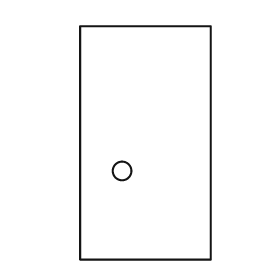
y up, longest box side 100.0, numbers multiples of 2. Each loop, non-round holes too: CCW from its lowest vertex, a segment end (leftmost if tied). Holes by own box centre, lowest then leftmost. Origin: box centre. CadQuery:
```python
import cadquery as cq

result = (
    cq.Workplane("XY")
    .moveTo(-28.0, -50.0)
    .lineTo(28.0, -50.0)
    .lineTo(28.0, 50.0)
    .lineTo(-28.0, 50.0)
    .close()
    .moveTo(-10.0, -12.0)
    .circle(4.0)
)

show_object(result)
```